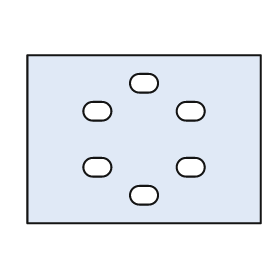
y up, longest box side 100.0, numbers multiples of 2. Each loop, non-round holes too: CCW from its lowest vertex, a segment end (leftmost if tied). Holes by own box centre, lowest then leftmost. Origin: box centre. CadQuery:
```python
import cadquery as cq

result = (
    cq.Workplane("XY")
    .moveTo(-50.0, -36.0)
    .lineTo(50.0, -36.0)
    .lineTo(50.0, 36.0)
    .lineTo(-50.0, 36.0)
    .close()
    .moveTo(-2.0, -28.0)
    .lineTo(2.0, -28.0)
    .threePointArc((6.0, -24.0), (2.0, -20.0))
    .lineTo(-2.0, -20.0)
    .threePointArc((-6.0, -24.0), (-2.0, -28.0))
    .close()
    .moveTo(-22.0, -16.0)
    .lineTo(-18.0, -16.0)
    .threePointArc((-14.0, -12.0), (-18.0, -8.0))
    .lineTo(-22.0, -8.0)
    .threePointArc((-26.0, -12.0), (-22.0, -16.0))
    .close()
    .moveTo(18.0, -16.0)
    .lineTo(22.0, -16.0)
    .threePointArc((26.0, -12.0), (22.0, -8.0))
    .lineTo(18.0, -8.0)
    .threePointArc((14.0, -12.0), (18.0, -16.0))
    .close()
    .moveTo(-22.0, 8.0)
    .lineTo(-18.0, 8.0)
    .threePointArc((-14.0, 12.0), (-18.0, 16.0))
    .lineTo(-22.0, 16.0)
    .threePointArc((-26.0, 12.0), (-22.0, 8.0))
    .close()
    .moveTo(18.0, 8.0)
    .lineTo(22.0, 8.0)
    .threePointArc((26.0, 12.0), (22.0, 16.0))
    .lineTo(18.0, 16.0)
    .threePointArc((14.0, 12.0), (18.0, 8.0))
    .close()
    .moveTo(-2.0, 20.0)
    .lineTo(2.0, 20.0)
    .threePointArc((6.0, 24.0), (2.0, 28.0))
    .lineTo(-2.0, 28.0)
    .threePointArc((-6.0, 24.0), (-2.0, 20.0))
    .close()
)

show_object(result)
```